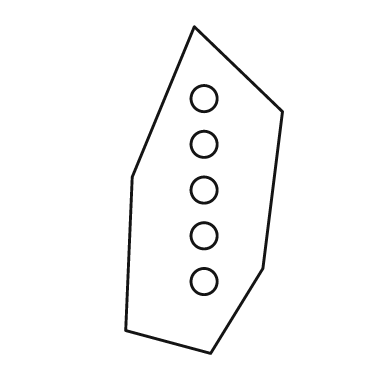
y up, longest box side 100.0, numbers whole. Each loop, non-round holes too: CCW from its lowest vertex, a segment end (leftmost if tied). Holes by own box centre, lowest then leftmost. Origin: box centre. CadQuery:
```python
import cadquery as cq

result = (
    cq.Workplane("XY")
    .moveTo(2.0, -50.0)
    .lineTo(18.0, -24.0)
    .lineTo(24.0, 24.0)
    .lineTo(-3.0, 50.0)
    .lineTo(-22.0, 4.0)
    .lineTo(-24.0, -43.0)
    .close()
    .moveTo(0.0, -28.0)
    .circle(4.0)
    .moveTo(0.0, -14.0)
    .circle(4.0)
    .moveTo(0.0, 0.0)
    .circle(4.0)
    .moveTo(0.0, 14.0)
    .circle(4.0)
    .moveTo(0.0, 28.0)
    .circle(4.0)
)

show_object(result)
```